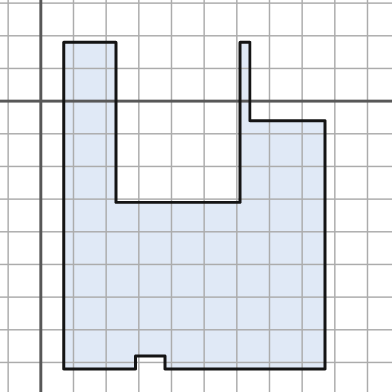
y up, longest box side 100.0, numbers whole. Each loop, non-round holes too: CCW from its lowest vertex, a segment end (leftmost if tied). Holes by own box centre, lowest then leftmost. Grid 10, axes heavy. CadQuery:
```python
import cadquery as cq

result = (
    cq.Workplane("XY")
    .moveTo(7.0, -82.0)
    .lineTo(29.0, -82.0)
    .lineTo(29.0, -78.0)
    .lineTo(38.0, -78.0)
    .lineTo(38.0, -82.0)
    .lineTo(87.0, -82.0)
    .lineTo(87.0, -6.0)
    .lineTo(64.0, -6.0)
    .lineTo(64.0, 18.0)
    .lineTo(61.0, 18.0)
    .lineTo(61.0, -31.0)
    .lineTo(23.0, -31.0)
    .lineTo(23.0, 18.0)
    .lineTo(7.0, 18.0)
    .close()
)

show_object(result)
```